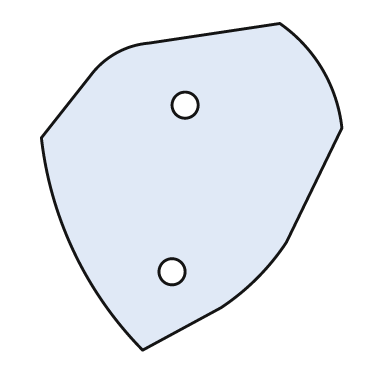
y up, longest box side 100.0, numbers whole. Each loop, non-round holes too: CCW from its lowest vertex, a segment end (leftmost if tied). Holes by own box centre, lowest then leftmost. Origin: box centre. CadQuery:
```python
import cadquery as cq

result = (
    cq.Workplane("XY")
    .moveTo(-15.0, -50.0)
    .lineTo(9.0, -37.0)
    .threePointArc((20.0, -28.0), (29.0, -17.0))
    .lineTo(46.0, 18.0)
    .threePointArc((40.0, 36.0), (27.0, 50.0))
    .lineTo(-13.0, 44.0)
    .threePointArc((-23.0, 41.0), (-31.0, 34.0))
    .lineTo(-46.0, 15.0)
    .threePointArc((-36.0, -20.0), (-15.0, -50.0))
    .close()
    .moveTo(-6.0, -26.0)
    .circle(4.0)
    .moveTo(-2.0, 25.0)
    .circle(4.0)
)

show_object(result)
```